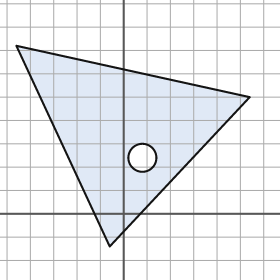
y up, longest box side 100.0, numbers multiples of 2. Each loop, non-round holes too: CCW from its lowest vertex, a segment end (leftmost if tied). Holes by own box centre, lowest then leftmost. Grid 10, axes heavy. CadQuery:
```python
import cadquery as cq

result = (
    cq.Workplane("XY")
    .moveTo(-6.0, -14.0)
    .lineTo(54.0, 50.0)
    .lineTo(-46.0, 72.0)
    .close()
    .moveTo(8.0, 24.0)
    .circle(6.0)
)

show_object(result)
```